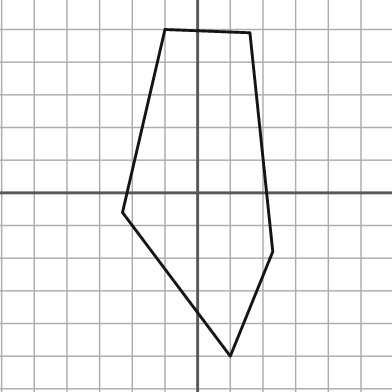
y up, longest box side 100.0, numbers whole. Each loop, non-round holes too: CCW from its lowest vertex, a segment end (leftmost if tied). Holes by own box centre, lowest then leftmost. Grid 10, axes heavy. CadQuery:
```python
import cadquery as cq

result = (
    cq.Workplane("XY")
    .moveTo(10.0, -50.0)
    .lineTo(23.0, -18.0)
    .lineTo(16.0, 49.0)
    .lineTo(-10.0, 50.0)
    .lineTo(-23.0, -6.0)
    .close()
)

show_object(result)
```